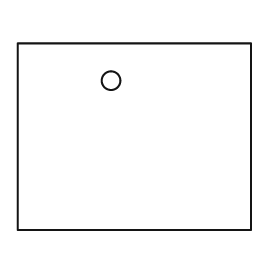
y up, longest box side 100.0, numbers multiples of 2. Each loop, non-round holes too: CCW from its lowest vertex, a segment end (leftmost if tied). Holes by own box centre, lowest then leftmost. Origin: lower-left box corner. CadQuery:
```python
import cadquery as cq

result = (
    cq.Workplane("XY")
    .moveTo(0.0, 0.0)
    .lineTo(100.0, 0.0)
    .lineTo(100.0, 80.0)
    .lineTo(0.0, 80.0)
    .close()
    .moveTo(40.0, 64.0)
    .circle(4.0)
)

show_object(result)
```